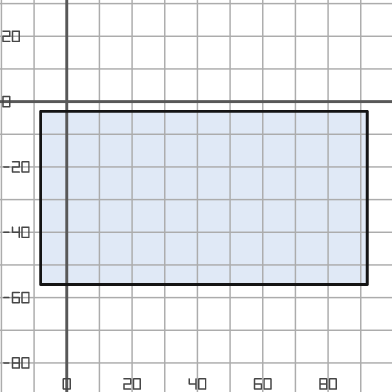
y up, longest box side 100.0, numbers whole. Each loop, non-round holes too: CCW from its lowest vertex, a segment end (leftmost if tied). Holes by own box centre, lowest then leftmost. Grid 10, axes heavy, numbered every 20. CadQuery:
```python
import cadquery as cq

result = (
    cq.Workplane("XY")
    .moveTo(-8.0, -56.0)
    .lineTo(92.0, -56.0)
    .lineTo(92.0, -3.0)
    .lineTo(-8.0, -3.0)
    .close()
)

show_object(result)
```